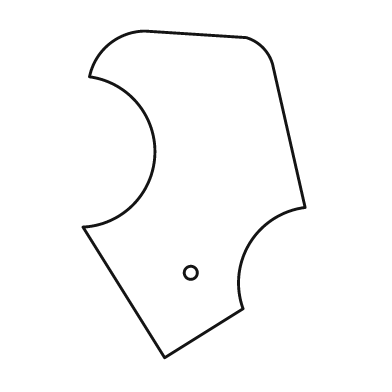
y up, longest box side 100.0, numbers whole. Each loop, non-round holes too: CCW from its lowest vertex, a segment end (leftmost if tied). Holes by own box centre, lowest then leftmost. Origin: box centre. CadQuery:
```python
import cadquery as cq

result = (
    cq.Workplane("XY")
    .moveTo(-9.0, -50.0)
    .lineTo(15.0, -35.0)
    .threePointArc((17.0, -15.0), (34.0, -4.0))
    .lineTo(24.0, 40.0)
    .threePointArc((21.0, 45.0), (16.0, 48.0))
    .lineTo(-15.0, 50.0)
    .threePointArc((-26.0, 46.0), (-32.0, 36.0))
    .threePointArc((-12.0, 12.0), (-34.0, -10.0))
    .close()
    .moveTo(-1.0, -24.0)
    .circle(2.0)
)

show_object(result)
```